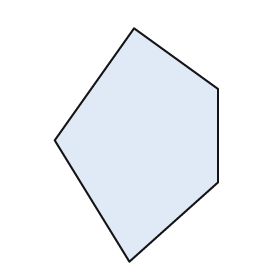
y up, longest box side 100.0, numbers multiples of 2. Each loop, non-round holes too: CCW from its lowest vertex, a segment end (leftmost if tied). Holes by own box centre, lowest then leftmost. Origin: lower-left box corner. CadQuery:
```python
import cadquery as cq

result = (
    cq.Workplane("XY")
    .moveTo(32.0, 0.0)
    .lineTo(70.0, 34.0)
    .lineTo(70.0, 74.0)
    .lineTo(34.0, 100.0)
    .lineTo(0.0, 52.0)
    .close()
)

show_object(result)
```